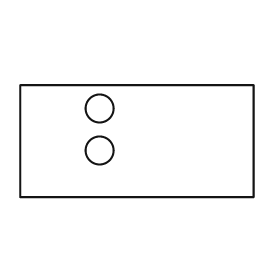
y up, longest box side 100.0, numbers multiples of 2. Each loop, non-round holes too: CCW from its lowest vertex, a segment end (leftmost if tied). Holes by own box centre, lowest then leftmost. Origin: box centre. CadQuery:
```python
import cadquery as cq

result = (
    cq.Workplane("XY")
    .moveTo(-50.0, -24.0)
    .lineTo(50.0, -24.0)
    .lineTo(50.0, 24.0)
    .lineTo(-50.0, 24.0)
    .close()
    .moveTo(-16.0, -4.0)
    .circle(6.0)
    .moveTo(-16.0, 14.0)
    .circle(6.0)
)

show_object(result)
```